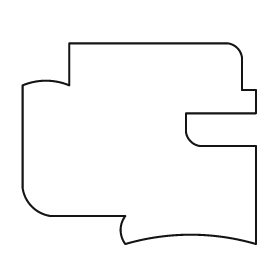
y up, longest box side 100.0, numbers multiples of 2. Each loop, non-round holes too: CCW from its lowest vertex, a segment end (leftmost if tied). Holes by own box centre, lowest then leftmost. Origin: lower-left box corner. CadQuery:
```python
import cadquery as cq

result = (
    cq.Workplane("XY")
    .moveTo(44.0, 0.0)
    .threePointArc((72.0, 4.0), (100.0, 0.0))
    .lineTo(100.0, 42.0)
    .lineTo(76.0, 42.0)
    .threePointArc((72.0, 44.0), (70.0, 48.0))
    .lineTo(70.0, 56.0)
    .lineTo(100.0, 56.0)
    .lineTo(100.0, 66.0)
    .lineTo(94.0, 66.0)
    .lineTo(94.0, 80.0)
    .threePointArc((92.0, 84.0), (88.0, 86.0))
    .lineTo(20.0, 86.0)
    .lineTo(20.0, 68.0)
    .threePointArc((10.0, 70.0), (0.0, 68.0))
    .lineTo(0.0, 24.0)
    .threePointArc((4.0, 16.0), (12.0, 12.0))
    .lineTo(44.0, 12.0)
    .threePointArc((42.0, 6.0), (44.0, 0.0))
    .close()
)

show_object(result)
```